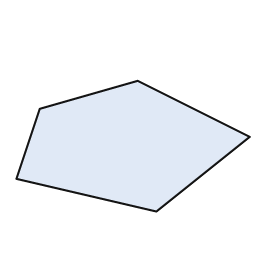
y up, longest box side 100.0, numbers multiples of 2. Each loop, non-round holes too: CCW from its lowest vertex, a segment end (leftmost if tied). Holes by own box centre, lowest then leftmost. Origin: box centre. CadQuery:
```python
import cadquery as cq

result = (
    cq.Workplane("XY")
    .moveTo(10.0, -28.0)
    .lineTo(50.0, 4.0)
    .lineTo(2.0, 28.0)
    .lineTo(-40.0, 16.0)
    .lineTo(-50.0, -14.0)
    .close()
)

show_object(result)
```